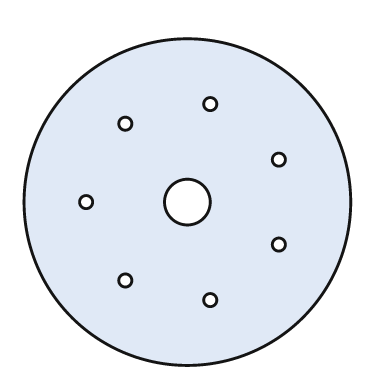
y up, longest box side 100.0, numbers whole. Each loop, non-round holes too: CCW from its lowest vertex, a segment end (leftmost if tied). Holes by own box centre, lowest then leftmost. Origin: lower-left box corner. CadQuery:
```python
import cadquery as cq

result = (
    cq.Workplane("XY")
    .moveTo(50.0, 50.0)
    .circle(50.0)
    .moveTo(57.0, 20.0)
    .circle(2.0)
    .moveTo(31.0, 26.0)
    .circle(2.0)
    .moveTo(78.0, 37.0)
    .circle(2.0)
    .moveTo(19.0, 50.0)
    .circle(2.0)
    .moveTo(50.0, 50.0)
    .circle(7.0)
    .moveTo(78.0, 63.0)
    .circle(2.0)
    .moveTo(31.0, 74.0)
    .circle(2.0)
    .moveTo(57.0, 80.0)
    .circle(2.0)
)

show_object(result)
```